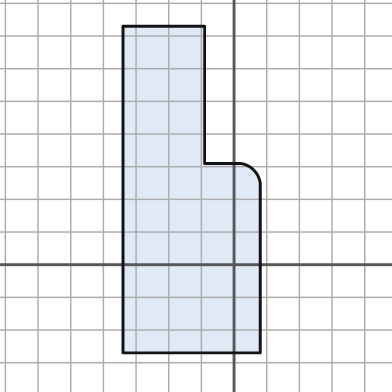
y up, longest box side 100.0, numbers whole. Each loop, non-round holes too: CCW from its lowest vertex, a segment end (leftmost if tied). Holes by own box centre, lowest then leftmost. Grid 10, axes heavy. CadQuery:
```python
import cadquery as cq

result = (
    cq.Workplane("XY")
    .moveTo(-34.0, -27.0)
    .lineTo(8.0, -27.0)
    .lineTo(8.0, 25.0)
    .threePointArc((6.0, 29.0), (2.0, 31.0))
    .lineTo(-9.0, 31.0)
    .lineTo(-9.0, 73.0)
    .lineTo(-34.0, 73.0)
    .close()
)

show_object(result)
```